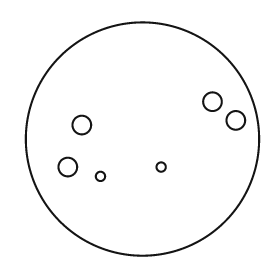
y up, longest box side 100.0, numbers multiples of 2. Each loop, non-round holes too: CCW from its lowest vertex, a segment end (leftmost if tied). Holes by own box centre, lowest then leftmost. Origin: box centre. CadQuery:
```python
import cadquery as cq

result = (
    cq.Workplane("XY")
    .moveTo(0.0, 0.0)
    .circle(50.0)
    .moveTo(-18.0, -16.0)
    .circle(2.0)
    .moveTo(-32.0, -12.0)
    .circle(4.0)
    .moveTo(8.0, -12.0)
    .circle(2.0)
    .moveTo(-26.0, 6.0)
    .circle(4.0)
    .moveTo(40.0, 8.0)
    .circle(4.0)
    .moveTo(30.0, 16.0)
    .circle(4.0)
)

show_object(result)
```